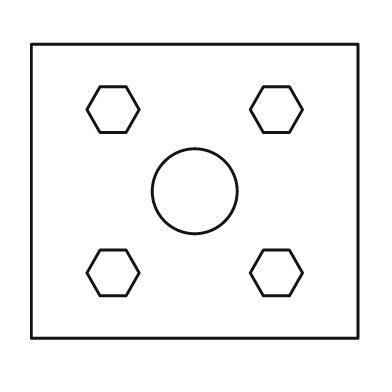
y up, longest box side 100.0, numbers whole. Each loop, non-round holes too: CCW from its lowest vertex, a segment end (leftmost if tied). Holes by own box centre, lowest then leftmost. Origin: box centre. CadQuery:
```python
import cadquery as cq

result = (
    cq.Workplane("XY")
    .moveTo(-50.0, -45.0)
    .lineTo(50.0, -45.0)
    .lineTo(50.0, 45.0)
    .lineTo(-50.0, 45.0)
    .close()
    .moveTo(-29.0, -32.0)
    .lineTo(-21.0, -32.0)
    .lineTo(-17.0, -25.0)
    .lineTo(-21.0, -18.0)
    .lineTo(-29.0, -18.0)
    .lineTo(-33.0, -25.0)
    .close()
    .moveTo(21.0, -32.0)
    .lineTo(29.0, -32.0)
    .lineTo(33.0, -25.0)
    .lineTo(29.0, -18.0)
    .lineTo(21.0, -18.0)
    .lineTo(17.0, -25.0)
    .close()
    .moveTo(0.0, 0.0)
    .circle(13.0)
    .moveTo(-29.0, 18.0)
    .lineTo(-21.0, 18.0)
    .lineTo(-17.0, 25.0)
    .lineTo(-21.0, 32.0)
    .lineTo(-29.0, 32.0)
    .lineTo(-33.0, 25.0)
    .close()
    .moveTo(21.0, 18.0)
    .lineTo(29.0, 18.0)
    .lineTo(33.0, 25.0)
    .lineTo(29.0, 32.0)
    .lineTo(21.0, 32.0)
    .lineTo(17.0, 25.0)
    .close()
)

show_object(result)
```